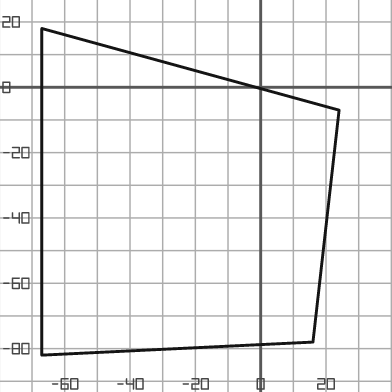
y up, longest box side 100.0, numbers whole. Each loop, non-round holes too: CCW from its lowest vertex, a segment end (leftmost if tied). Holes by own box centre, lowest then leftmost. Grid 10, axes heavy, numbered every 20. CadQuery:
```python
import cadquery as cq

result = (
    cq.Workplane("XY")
    .moveTo(-67.0, -82.0)
    .lineTo(16.0, -78.0)
    .lineTo(24.0, -7.0)
    .lineTo(-67.0, 18.0)
    .close()
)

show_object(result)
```